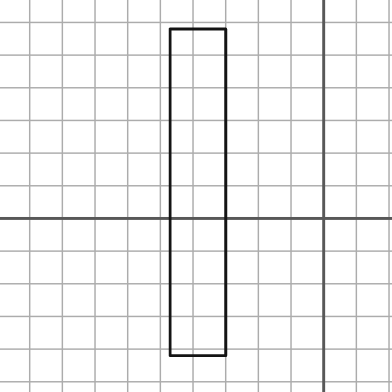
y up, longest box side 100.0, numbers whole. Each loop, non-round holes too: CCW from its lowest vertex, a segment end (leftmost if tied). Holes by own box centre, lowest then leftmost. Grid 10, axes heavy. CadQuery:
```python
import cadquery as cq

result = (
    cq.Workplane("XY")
    .moveTo(-47.0, -42.0)
    .lineTo(-30.0, -42.0)
    .lineTo(-30.0, 58.0)
    .lineTo(-47.0, 58.0)
    .close()
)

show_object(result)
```